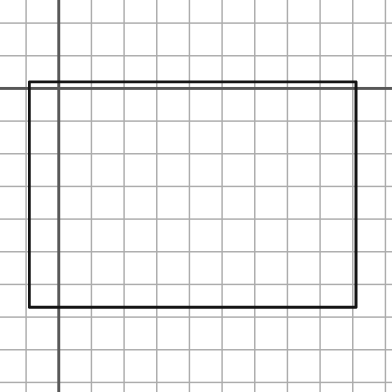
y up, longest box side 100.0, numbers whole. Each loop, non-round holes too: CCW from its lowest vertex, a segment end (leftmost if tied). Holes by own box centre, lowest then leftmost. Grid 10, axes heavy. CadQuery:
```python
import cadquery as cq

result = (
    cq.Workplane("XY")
    .moveTo(-9.0, -67.0)
    .lineTo(91.0, -67.0)
    .lineTo(91.0, 2.0)
    .lineTo(-9.0, 2.0)
    .close()
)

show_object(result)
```